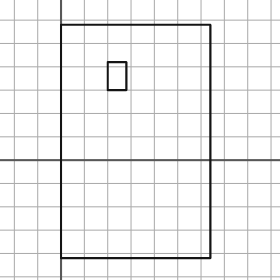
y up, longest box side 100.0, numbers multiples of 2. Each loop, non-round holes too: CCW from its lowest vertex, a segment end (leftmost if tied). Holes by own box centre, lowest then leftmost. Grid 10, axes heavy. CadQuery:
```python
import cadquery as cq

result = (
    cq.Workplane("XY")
    .moveTo(0.0, -42.0)
    .lineTo(64.0, -42.0)
    .lineTo(64.0, 58.0)
    .lineTo(0.0, 58.0)
    .close()
    .moveTo(20.0, 30.0)
    .lineTo(28.0, 30.0)
    .lineTo(28.0, 42.0)
    .lineTo(20.0, 42.0)
    .close()
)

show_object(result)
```